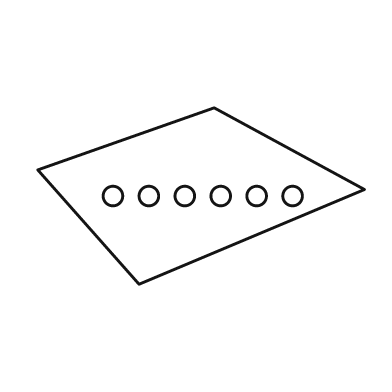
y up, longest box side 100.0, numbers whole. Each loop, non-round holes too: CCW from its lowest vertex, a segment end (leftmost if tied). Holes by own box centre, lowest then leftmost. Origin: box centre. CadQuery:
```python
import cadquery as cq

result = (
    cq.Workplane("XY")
    .moveTo(-19.0, -27.0)
    .lineTo(50.0, 2.0)
    .lineTo(4.0, 27.0)
    .lineTo(-50.0, 8.0)
    .close()
    .moveTo(-27.0, 0.0)
    .circle(3.0)
    .moveTo(-16.0, 0.0)
    .circle(3.0)
    .moveTo(-5.0, 0.0)
    .circle(3.0)
    .moveTo(6.0, 0.0)
    .circle(3.0)
    .moveTo(17.0, 0.0)
    .circle(3.0)
    .moveTo(28.0, 0.0)
    .circle(3.0)
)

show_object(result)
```